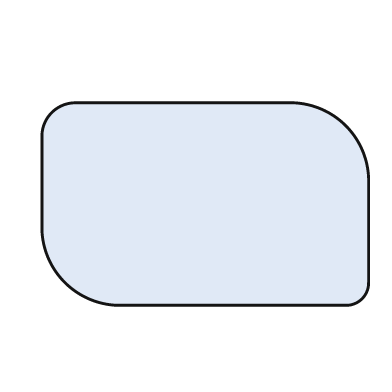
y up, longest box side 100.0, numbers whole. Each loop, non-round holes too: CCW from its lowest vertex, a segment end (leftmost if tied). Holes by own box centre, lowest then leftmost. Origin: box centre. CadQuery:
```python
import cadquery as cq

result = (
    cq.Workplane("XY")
    .moveTo(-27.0, -31.0)
    .lineTo(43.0, -31.0)
    .threePointArc((48.0, -29.0), (50.0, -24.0))
    .lineTo(50.0, 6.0)
    .threePointArc((43.0, 24.0), (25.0, 31.0))
    .lineTo(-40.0, 31.0)
    .threePointArc((-47.0, 28.0), (-50.0, 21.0))
    .lineTo(-50.0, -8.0)
    .threePointArc((-43.0, -24.0), (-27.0, -31.0))
    .close()
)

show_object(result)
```